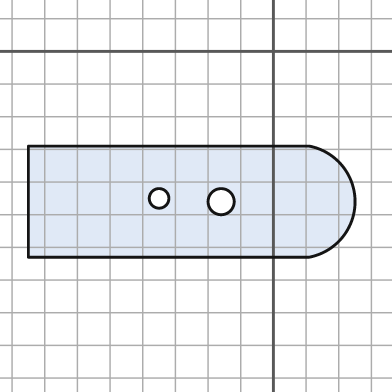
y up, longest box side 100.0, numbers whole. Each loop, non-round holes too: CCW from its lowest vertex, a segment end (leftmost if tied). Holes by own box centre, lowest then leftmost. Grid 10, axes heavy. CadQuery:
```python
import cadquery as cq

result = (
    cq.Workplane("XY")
    .moveTo(-75.0, -63.0)
    .lineTo(11.0, -63.0)
    .threePointArc((25.0, -46.0), (11.0, -29.0))
    .lineTo(-75.0, -29.0)
    .close()
    .moveTo(-16.0, -46.0)
    .circle(4.0)
    .moveTo(-35.0, -45.0)
    .circle(3.0)
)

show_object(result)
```